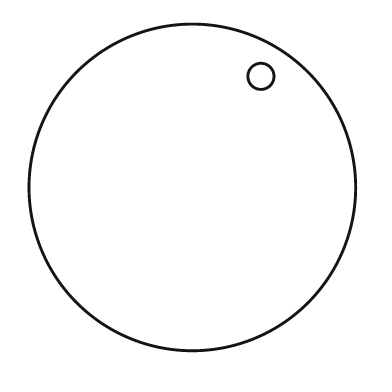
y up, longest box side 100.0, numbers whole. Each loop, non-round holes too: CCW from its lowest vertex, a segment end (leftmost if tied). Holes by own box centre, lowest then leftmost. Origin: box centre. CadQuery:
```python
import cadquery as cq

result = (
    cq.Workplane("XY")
    .moveTo(0.0, 0.0)
    .circle(50.0)
    .moveTo(21.0, 34.0)
    .circle(4.0)
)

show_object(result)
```